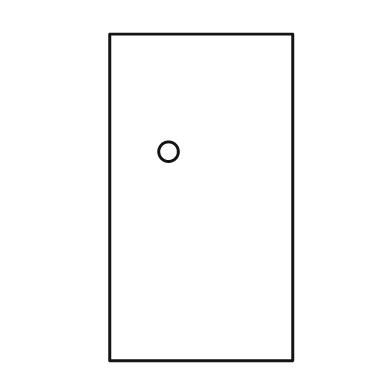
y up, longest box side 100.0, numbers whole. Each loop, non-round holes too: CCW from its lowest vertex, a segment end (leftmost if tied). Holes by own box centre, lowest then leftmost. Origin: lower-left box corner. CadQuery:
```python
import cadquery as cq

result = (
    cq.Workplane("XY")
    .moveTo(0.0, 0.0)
    .lineTo(56.0, 0.0)
    .lineTo(56.0, 100.0)
    .lineTo(0.0, 100.0)
    .close()
    .moveTo(18.0, 64.0)
    .circle(3.0)
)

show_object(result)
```